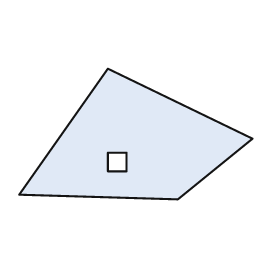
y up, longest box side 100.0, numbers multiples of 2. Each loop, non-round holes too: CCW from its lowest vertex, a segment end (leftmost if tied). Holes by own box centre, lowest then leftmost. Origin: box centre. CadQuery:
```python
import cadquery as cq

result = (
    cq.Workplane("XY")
    .moveTo(18.0, -28.0)
    .lineTo(50.0, -2.0)
    .lineTo(-12.0, 28.0)
    .lineTo(-50.0, -26.0)
    .close()
    .moveTo(-12.0, -16.0)
    .lineTo(-4.0, -16.0)
    .lineTo(-4.0, -8.0)
    .lineTo(-12.0, -8.0)
    .close()
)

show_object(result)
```